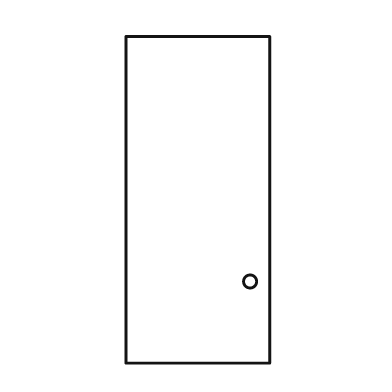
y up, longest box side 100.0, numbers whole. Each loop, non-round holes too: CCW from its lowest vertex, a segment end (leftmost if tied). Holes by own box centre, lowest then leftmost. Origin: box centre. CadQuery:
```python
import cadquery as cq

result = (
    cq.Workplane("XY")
    .moveTo(-22.0, -50.0)
    .lineTo(22.0, -50.0)
    .lineTo(22.0, 50.0)
    .lineTo(-22.0, 50.0)
    .close()
    .moveTo(16.0, -25.0)
    .circle(2.0)
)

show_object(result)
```